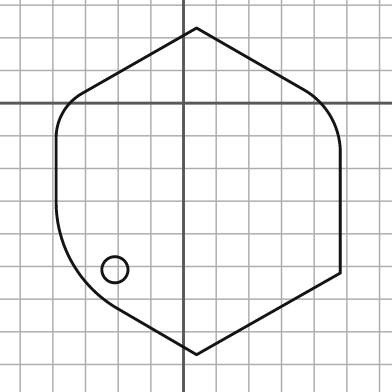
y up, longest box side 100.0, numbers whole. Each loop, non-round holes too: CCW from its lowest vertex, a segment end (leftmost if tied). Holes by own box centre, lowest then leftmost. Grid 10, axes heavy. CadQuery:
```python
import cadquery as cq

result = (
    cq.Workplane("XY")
    .moveTo(4.0, -77.0)
    .lineTo(48.0, -52.0)
    .lineTo(48.0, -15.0)
    .threePointArc((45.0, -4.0), (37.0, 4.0))
    .lineTo(4.0, 23.0)
    .lineTo(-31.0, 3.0)
    .threePointArc((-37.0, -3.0), (-39.0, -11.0))
    .lineTo(-39.0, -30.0)
    .threePointArc((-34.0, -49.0), (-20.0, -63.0))
    .close()
    .moveTo(-21.0, -51.0)
    .circle(4.0)
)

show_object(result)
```